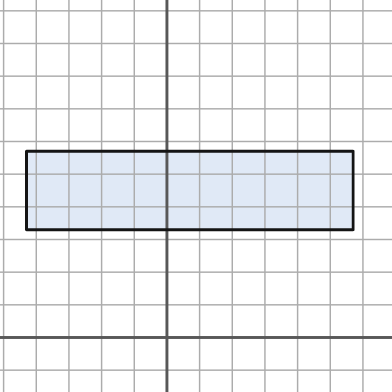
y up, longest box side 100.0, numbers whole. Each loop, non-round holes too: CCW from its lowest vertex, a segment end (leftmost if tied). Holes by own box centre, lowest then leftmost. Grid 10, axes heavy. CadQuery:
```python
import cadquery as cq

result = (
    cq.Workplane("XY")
    .moveTo(-43.0, 33.0)
    .lineTo(57.0, 33.0)
    .lineTo(57.0, 57.0)
    .lineTo(-43.0, 57.0)
    .close()
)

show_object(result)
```